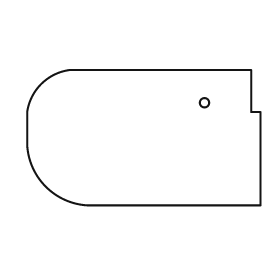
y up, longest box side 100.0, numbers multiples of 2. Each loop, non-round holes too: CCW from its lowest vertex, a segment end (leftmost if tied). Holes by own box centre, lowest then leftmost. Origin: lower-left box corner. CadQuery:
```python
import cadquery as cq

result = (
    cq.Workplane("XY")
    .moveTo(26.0, 0.0)
    .lineTo(100.0, 0.0)
    .lineTo(100.0, 40.0)
    .lineTo(96.0, 40.0)
    .lineTo(96.0, 58.0)
    .lineTo(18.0, 58.0)
    .threePointArc((6.0, 52.0), (0.0, 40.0))
    .lineTo(0.0, 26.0)
    .threePointArc((8.0, 8.0), (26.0, 0.0))
    .close()
    .moveTo(76.0, 44.0)
    .circle(2.0)
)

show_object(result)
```